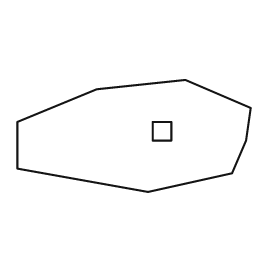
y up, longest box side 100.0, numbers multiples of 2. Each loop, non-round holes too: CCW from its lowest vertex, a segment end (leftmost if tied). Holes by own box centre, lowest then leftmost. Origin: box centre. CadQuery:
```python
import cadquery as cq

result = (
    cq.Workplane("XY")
    .moveTo(6.0, -24.0)
    .lineTo(42.0, -16.0)
    .lineTo(48.0, -2.0)
    .lineTo(50.0, 12.0)
    .lineTo(22.0, 24.0)
    .lineTo(-16.0, 20.0)
    .lineTo(-50.0, 6.0)
    .lineTo(-50.0, -14.0)
    .close()
    .moveTo(8.0, -2.0)
    .lineTo(16.0, -2.0)
    .lineTo(16.0, 6.0)
    .lineTo(8.0, 6.0)
    .close()
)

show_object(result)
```